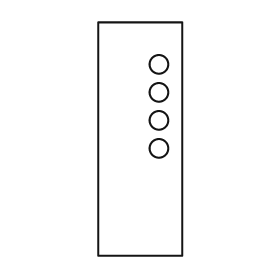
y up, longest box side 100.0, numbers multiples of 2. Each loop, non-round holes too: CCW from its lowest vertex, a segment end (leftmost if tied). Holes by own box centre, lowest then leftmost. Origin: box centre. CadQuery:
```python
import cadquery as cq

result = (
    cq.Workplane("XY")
    .moveTo(-18.0, -50.0)
    .lineTo(18.0, -50.0)
    .lineTo(18.0, 50.0)
    .lineTo(-18.0, 50.0)
    .close()
    .moveTo(8.0, -4.0)
    .circle(4.0)
    .moveTo(8.0, 8.0)
    .circle(4.0)
    .moveTo(8.0, 20.0)
    .circle(4.0)
    .moveTo(8.0, 32.0)
    .circle(4.0)
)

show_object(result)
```